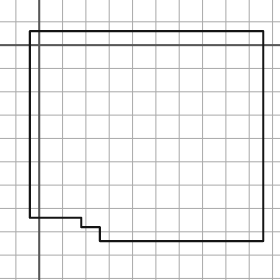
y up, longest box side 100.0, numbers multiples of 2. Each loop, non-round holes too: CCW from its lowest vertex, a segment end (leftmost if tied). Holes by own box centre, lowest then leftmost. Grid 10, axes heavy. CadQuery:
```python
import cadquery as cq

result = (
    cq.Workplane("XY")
    .moveTo(26.0, -84.0)
    .lineTo(96.0, -84.0)
    .lineTo(96.0, 6.0)
    .lineTo(-4.0, 6.0)
    .lineTo(-4.0, -74.0)
    .lineTo(18.0, -74.0)
    .lineTo(18.0, -78.0)
    .lineTo(26.0, -78.0)
    .close()
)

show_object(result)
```